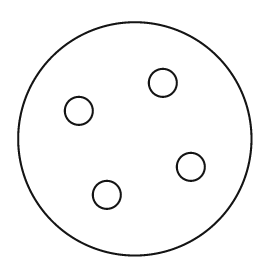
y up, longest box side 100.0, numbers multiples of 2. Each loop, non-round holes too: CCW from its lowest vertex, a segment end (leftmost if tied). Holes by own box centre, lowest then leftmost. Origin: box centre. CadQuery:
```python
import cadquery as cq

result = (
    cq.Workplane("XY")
    .moveTo(0.0, 0.0)
    .circle(50.0)
    .moveTo(-12.0, -24.0)
    .circle(6.0)
    .moveTo(24.0, -12.0)
    .circle(6.0)
    .moveTo(-24.0, 12.0)
    .circle(6.0)
    .moveTo(12.0, 24.0)
    .circle(6.0)
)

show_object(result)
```